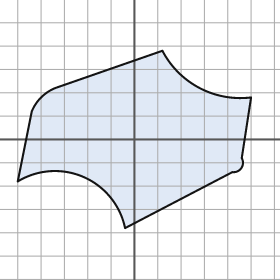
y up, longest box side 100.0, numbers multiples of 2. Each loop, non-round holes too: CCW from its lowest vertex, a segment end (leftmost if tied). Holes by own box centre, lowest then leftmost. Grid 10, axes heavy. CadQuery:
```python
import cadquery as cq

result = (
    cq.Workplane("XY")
    .moveTo(-4.0, -38.0)
    .lineTo(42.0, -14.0)
    .threePointArc((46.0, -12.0), (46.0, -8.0))
    .lineTo(50.0, 18.0)
    .threePointArc((28.0, 22.0), (12.0, 38.0))
    .lineTo(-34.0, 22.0)
    .threePointArc((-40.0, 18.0), (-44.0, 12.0))
    .lineTo(-50.0, -18.0)
    .threePointArc((-22.0, -16.0), (-4.0, -38.0))
    .close()
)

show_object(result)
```